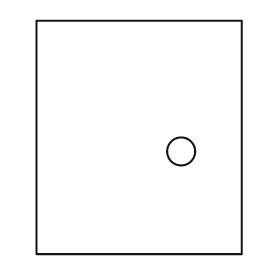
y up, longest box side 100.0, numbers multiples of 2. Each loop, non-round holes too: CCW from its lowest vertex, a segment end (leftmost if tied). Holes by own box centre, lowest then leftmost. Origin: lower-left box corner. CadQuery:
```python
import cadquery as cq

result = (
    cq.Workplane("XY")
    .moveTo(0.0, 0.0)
    .lineTo(88.0, 0.0)
    .lineTo(88.0, 100.0)
    .lineTo(0.0, 100.0)
    .close()
    .moveTo(62.0, 44.0)
    .circle(6.0)
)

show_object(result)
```